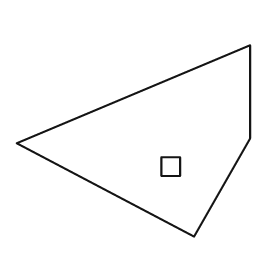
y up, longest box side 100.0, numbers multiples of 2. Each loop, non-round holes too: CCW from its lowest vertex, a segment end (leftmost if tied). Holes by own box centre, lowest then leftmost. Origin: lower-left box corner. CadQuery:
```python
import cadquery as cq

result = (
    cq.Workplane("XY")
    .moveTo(76.0, 0.0)
    .lineTo(100.0, 42.0)
    .lineTo(100.0, 82.0)
    .lineTo(0.0, 40.0)
    .close()
    .moveTo(62.0, 26.0)
    .lineTo(70.0, 26.0)
    .lineTo(70.0, 34.0)
    .lineTo(62.0, 34.0)
    .close()
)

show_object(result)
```